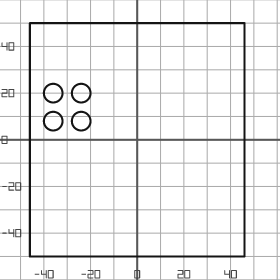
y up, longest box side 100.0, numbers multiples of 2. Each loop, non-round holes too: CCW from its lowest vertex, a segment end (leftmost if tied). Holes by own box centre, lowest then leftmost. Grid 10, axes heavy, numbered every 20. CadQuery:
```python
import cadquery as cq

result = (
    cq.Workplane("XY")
    .moveTo(-46.0, -50.0)
    .lineTo(46.0, -50.0)
    .lineTo(46.0, 50.0)
    .lineTo(-46.0, 50.0)
    .close()
    .moveTo(-36.0, 8.0)
    .circle(4.0)
    .moveTo(-24.0, 8.0)
    .circle(4.0)
    .moveTo(-36.0, 20.0)
    .circle(4.0)
    .moveTo(-24.0, 20.0)
    .circle(4.0)
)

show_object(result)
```